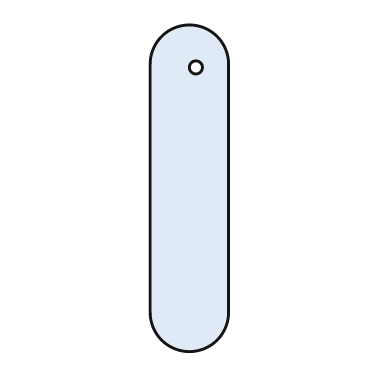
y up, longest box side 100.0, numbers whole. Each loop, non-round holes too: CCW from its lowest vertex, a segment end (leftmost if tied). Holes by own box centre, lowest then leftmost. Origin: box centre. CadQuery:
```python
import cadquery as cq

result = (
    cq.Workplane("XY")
    .moveTo(-12.0, -38.0)
    .threePointArc((0.0, -50.0), (12.0, -38.0))
    .lineTo(12.0, 38.0)
    .threePointArc((0.0, 50.0), (-12.0, 38.0))
    .close()
    .moveTo(2.0, 37.0)
    .circle(2.0)
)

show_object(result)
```